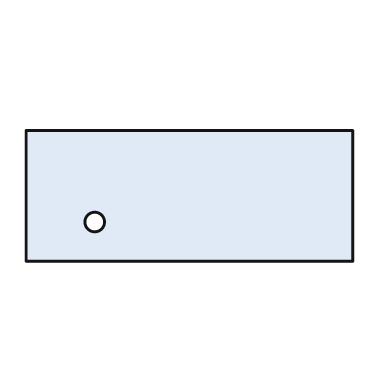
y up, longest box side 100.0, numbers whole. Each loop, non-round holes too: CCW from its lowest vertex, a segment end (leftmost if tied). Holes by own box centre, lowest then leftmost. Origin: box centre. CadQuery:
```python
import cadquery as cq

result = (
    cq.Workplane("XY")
    .moveTo(-50.0, -20.0)
    .lineTo(50.0, -20.0)
    .lineTo(50.0, 20.0)
    .lineTo(-50.0, 20.0)
    .close()
    .moveTo(-29.0, -8.0)
    .circle(3.0)
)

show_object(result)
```